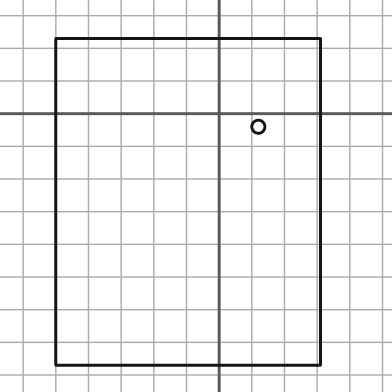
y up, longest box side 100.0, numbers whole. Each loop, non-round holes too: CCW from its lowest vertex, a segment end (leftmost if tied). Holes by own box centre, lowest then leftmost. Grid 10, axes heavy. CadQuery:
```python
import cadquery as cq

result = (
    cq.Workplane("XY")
    .moveTo(-50.0, -77.0)
    .lineTo(31.0, -77.0)
    .lineTo(31.0, 23.0)
    .lineTo(-50.0, 23.0)
    .close()
    .moveTo(12.0, -4.0)
    .circle(2.0)
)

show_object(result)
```